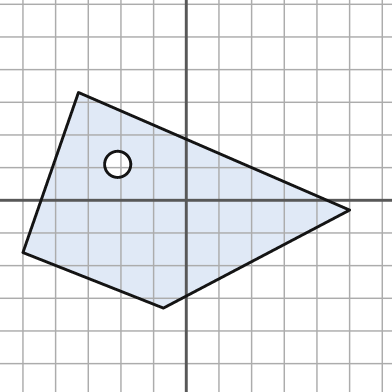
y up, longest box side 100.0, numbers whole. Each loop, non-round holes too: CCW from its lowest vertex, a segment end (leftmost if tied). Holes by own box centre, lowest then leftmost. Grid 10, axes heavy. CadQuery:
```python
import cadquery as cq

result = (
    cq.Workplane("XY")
    .moveTo(-7.0, -33.0)
    .lineTo(50.0, -3.0)
    .lineTo(-33.0, 33.0)
    .lineTo(-50.0, -16.0)
    .close()
    .moveTo(-21.0, 11.0)
    .circle(4.0)
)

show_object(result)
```